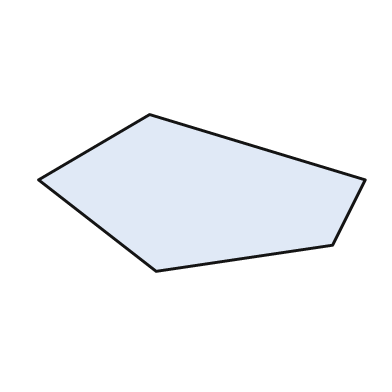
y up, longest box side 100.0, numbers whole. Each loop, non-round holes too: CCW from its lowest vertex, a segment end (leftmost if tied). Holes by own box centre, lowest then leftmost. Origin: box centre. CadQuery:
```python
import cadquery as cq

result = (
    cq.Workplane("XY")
    .moveTo(-14.0, -24.0)
    .lineTo(40.0, -16.0)
    .lineTo(50.0, 4.0)
    .lineTo(-16.0, 24.0)
    .lineTo(-50.0, 4.0)
    .close()
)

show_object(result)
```